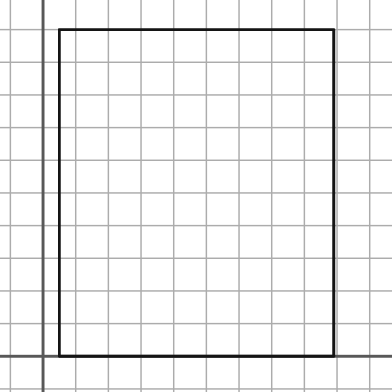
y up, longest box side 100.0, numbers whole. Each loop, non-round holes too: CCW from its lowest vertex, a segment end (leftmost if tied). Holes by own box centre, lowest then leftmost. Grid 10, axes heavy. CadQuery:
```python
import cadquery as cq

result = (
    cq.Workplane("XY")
    .moveTo(5.0, 0.0)
    .lineTo(89.0, 0.0)
    .lineTo(89.0, 100.0)
    .lineTo(5.0, 100.0)
    .close()
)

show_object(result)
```